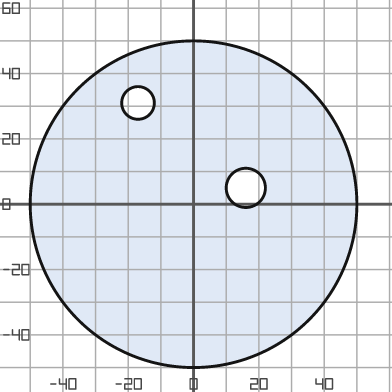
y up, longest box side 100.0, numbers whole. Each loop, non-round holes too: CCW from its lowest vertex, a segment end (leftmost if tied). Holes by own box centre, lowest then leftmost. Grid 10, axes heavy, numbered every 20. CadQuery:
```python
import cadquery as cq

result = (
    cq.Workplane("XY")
    .moveTo(0.0, 0.0)
    .circle(50.0)
    .moveTo(16.0, 5.0)
    .circle(6.0)
    .moveTo(-17.0, 31.0)
    .circle(5.0)
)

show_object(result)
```